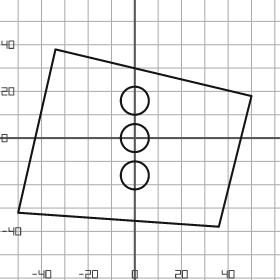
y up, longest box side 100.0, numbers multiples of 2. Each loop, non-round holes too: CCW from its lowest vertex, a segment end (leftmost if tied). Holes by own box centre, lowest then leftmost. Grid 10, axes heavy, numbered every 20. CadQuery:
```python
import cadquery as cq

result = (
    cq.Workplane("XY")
    .moveTo(36.0, -38.0)
    .lineTo(50.0, 18.0)
    .lineTo(-34.0, 38.0)
    .lineTo(-50.0, -32.0)
    .close()
    .moveTo(0.0, -16.0)
    .circle(6.0)
    .moveTo(0.0, 0.0)
    .circle(6.0)
    .moveTo(0.0, 16.0)
    .circle(6.0)
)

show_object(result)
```